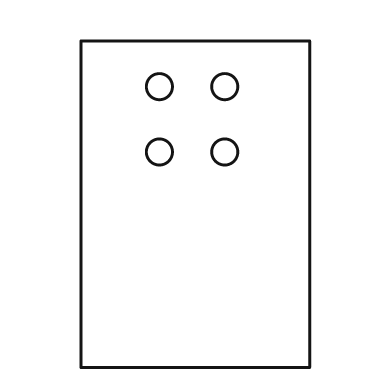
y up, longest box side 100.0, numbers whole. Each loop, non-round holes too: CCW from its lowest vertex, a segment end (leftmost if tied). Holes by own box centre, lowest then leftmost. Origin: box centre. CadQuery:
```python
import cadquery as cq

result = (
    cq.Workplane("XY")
    .moveTo(-35.0, -50.0)
    .lineTo(35.0, -50.0)
    .lineTo(35.0, 50.0)
    .lineTo(-35.0, 50.0)
    .close()
    .moveTo(-11.0, 16.0)
    .circle(4.0)
    .moveTo(9.0, 16.0)
    .circle(4.0)
    .moveTo(-11.0, 36.0)
    .circle(4.0)
    .moveTo(9.0, 36.0)
    .circle(4.0)
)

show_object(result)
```